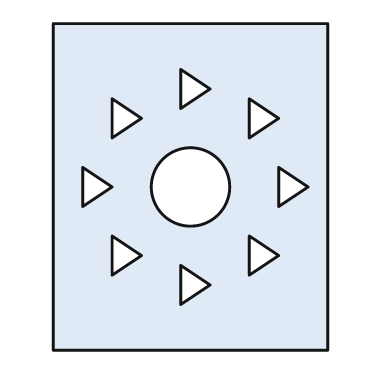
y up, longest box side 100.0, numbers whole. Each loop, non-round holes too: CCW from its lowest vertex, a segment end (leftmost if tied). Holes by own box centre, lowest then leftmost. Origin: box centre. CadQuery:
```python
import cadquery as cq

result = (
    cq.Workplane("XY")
    .moveTo(-42.0, -50.0)
    .lineTo(42.0, -50.0)
    .lineTo(42.0, 50.0)
    .lineTo(-42.0, 50.0)
    .close()
    .moveTo(-3.0, -36.0)
    .lineTo(6.0, -30.0)
    .lineTo(-3.0, -24.0)
    .close()
    .moveTo(-24.0, -27.0)
    .lineTo(-15.0, -21.0)
    .lineTo(-24.0, -15.0)
    .close()
    .moveTo(18.0, -27.0)
    .lineTo(27.0, -21.0)
    .lineTo(18.0, -15.0)
    .close()
    .moveTo(-33.0, -6.0)
    .lineTo(-24.0, 0.0)
    .lineTo(-33.0, 6.0)
    .close()
    .moveTo(0.0, 0.0)
    .circle(12.0)
    .moveTo(27.0, -6.0)
    .lineTo(36.0, 0.0)
    .lineTo(27.0, 6.0)
    .close()
    .moveTo(-24.0, 15.0)
    .lineTo(-15.0, 21.0)
    .lineTo(-24.0, 27.0)
    .close()
    .moveTo(18.0, 15.0)
    .lineTo(27.0, 21.0)
    .lineTo(18.0, 27.0)
    .close()
    .moveTo(-3.0, 24.0)
    .lineTo(6.0, 30.0)
    .lineTo(-3.0, 36.0)
    .close()
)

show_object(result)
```